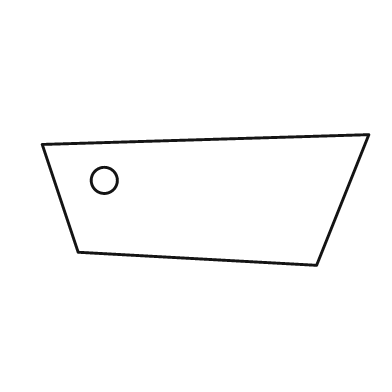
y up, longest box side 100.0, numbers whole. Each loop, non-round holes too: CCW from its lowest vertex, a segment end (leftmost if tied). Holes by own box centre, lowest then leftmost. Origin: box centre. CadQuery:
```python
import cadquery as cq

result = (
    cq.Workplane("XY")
    .moveTo(34.0, -20.0)
    .lineTo(50.0, 20.0)
    .lineTo(-50.0, 17.0)
    .lineTo(-39.0, -16.0)
    .close()
    .moveTo(-31.0, 6.0)
    .circle(4.0)
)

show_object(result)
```